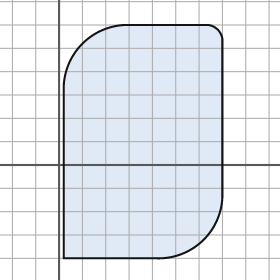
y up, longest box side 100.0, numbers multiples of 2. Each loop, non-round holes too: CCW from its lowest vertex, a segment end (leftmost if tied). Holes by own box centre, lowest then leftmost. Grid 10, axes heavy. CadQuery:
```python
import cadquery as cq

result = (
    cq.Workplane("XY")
    .moveTo(2.0, -40.0)
    .lineTo(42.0, -40.0)
    .threePointArc((62.0, -32.0), (70.0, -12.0))
    .lineTo(70.0, 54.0)
    .threePointArc((68.0, 58.0), (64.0, 60.0))
    .lineTo(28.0, 60.0)
    .threePointArc((10.0, 52.0), (2.0, 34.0))
    .close()
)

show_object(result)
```